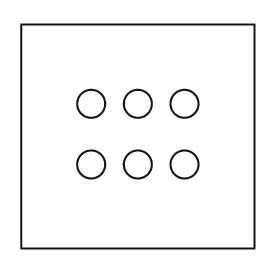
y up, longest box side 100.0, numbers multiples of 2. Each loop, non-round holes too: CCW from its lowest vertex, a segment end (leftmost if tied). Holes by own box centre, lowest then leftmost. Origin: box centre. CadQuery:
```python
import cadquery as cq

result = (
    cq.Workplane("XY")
    .moveTo(-50.0, -48.0)
    .lineTo(50.0, -48.0)
    .lineTo(50.0, 48.0)
    .lineTo(-50.0, 48.0)
    .close()
    .moveTo(-20.0, -12.0)
    .circle(6.0)
    .moveTo(0.0, -12.0)
    .circle(6.0)
    .moveTo(20.0, -12.0)
    .circle(6.0)
    .moveTo(-20.0, 14.0)
    .circle(6.0)
    .moveTo(0.0, 14.0)
    .circle(6.0)
    .moveTo(20.0, 14.0)
    .circle(6.0)
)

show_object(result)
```